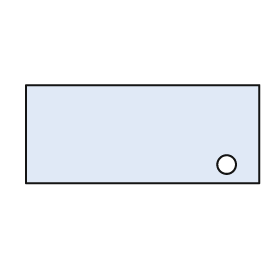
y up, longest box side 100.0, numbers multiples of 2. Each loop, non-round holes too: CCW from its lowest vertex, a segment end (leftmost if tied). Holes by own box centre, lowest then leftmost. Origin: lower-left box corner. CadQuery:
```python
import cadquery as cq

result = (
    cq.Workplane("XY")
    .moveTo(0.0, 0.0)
    .lineTo(100.0, 0.0)
    .lineTo(100.0, 42.0)
    .lineTo(0.0, 42.0)
    .close()
    .moveTo(86.0, 8.0)
    .circle(4.0)
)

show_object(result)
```